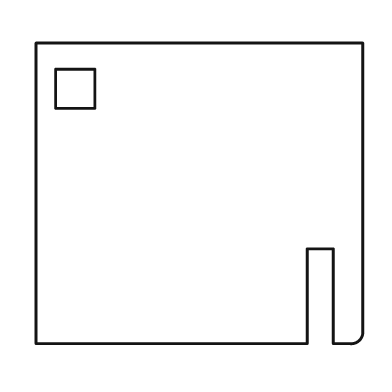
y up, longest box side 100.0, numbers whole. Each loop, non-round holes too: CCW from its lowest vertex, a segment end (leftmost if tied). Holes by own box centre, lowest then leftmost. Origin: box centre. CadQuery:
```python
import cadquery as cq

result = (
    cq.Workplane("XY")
    .moveTo(-50.0, -46.0)
    .lineTo(33.0, -46.0)
    .lineTo(33.0, -17.0)
    .lineTo(41.0, -17.0)
    .lineTo(41.0, -46.0)
    .lineTo(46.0, -46.0)
    .threePointArc((49.0, -45.0), (50.0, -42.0))
    .lineTo(50.0, 46.0)
    .lineTo(-50.0, 46.0)
    .close()
    .moveTo(-44.0, 26.0)
    .lineTo(-32.0, 26.0)
    .lineTo(-32.0, 38.0)
    .lineTo(-44.0, 38.0)
    .close()
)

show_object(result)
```